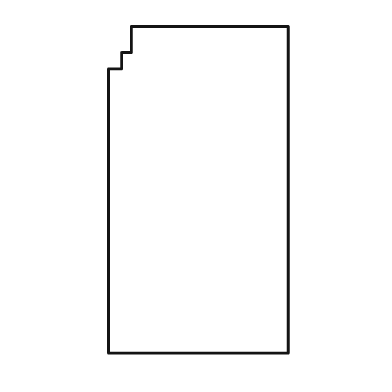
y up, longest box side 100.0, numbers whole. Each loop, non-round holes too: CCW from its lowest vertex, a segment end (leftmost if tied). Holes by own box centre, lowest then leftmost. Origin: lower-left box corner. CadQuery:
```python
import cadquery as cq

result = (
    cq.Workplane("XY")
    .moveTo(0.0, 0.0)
    .lineTo(55.0, 0.0)
    .lineTo(55.0, 100.0)
    .lineTo(7.0, 100.0)
    .lineTo(7.0, 92.0)
    .lineTo(4.0, 92.0)
    .lineTo(4.0, 87.0)
    .lineTo(0.0, 87.0)
    .close()
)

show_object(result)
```